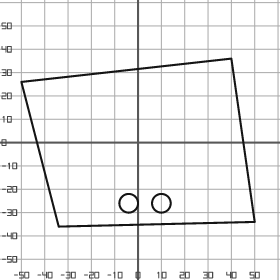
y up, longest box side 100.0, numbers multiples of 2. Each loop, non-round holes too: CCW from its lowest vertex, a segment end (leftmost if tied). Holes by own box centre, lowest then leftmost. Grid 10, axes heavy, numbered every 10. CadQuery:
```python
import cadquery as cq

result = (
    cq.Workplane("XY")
    .moveTo(-34.0, -36.0)
    .lineTo(50.0, -34.0)
    .lineTo(40.0, 36.0)
    .lineTo(-50.0, 26.0)
    .close()
    .moveTo(-4.0, -26.0)
    .circle(4.0)
    .moveTo(10.0, -26.0)
    .circle(4.0)
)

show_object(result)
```